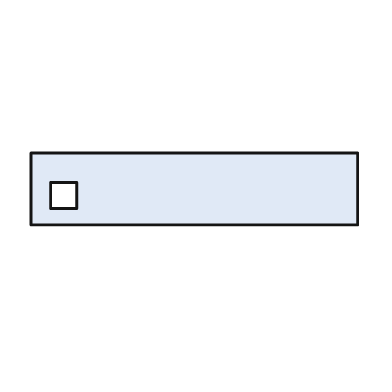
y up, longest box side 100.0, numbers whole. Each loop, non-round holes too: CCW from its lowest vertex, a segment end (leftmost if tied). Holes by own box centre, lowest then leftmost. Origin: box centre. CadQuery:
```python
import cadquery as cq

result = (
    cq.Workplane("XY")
    .moveTo(-50.0, -11.0)
    .lineTo(50.0, -11.0)
    .lineTo(50.0, 11.0)
    .lineTo(-50.0, 11.0)
    .close()
    .moveTo(-44.0, -6.0)
    .lineTo(-36.0, -6.0)
    .lineTo(-36.0, 2.0)
    .lineTo(-44.0, 2.0)
    .close()
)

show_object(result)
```